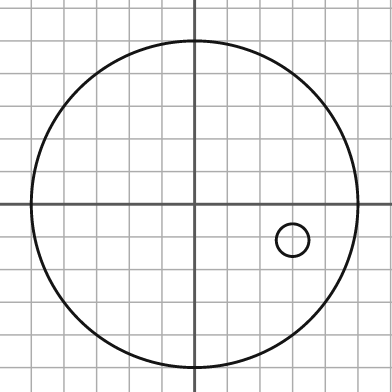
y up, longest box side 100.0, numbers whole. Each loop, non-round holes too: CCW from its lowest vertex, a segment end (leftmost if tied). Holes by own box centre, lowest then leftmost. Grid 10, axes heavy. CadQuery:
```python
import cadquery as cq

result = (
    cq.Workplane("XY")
    .moveTo(0.0, 0.0)
    .circle(50.0)
    .moveTo(30.0, -11.0)
    .circle(5.0)
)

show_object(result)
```